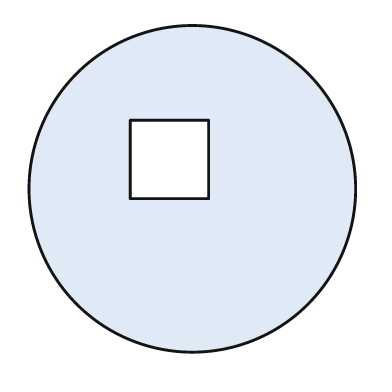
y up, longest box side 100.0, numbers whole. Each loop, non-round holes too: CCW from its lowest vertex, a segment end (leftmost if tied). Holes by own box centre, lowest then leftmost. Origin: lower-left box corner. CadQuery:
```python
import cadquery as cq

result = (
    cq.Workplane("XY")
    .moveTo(50.0, 50.0)
    .circle(50.0)
    .moveTo(31.0, 47.0)
    .lineTo(55.0, 47.0)
    .lineTo(55.0, 71.0)
    .lineTo(31.0, 71.0)
    .close()
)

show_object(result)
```